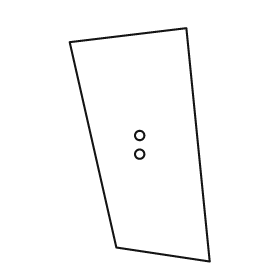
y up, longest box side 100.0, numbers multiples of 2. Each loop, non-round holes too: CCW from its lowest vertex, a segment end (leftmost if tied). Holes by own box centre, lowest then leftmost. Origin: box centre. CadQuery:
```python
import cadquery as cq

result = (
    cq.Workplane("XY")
    .moveTo(30.0, -50.0)
    .lineTo(20.0, 50.0)
    .lineTo(-30.0, 44.0)
    .lineTo(-10.0, -44.0)
    .close()
    .moveTo(0.0, -4.0)
    .circle(2.0)
    .moveTo(0.0, 4.0)
    .circle(2.0)
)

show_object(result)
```